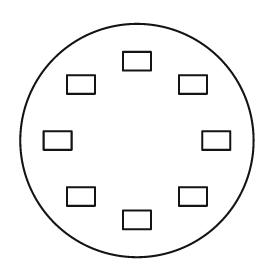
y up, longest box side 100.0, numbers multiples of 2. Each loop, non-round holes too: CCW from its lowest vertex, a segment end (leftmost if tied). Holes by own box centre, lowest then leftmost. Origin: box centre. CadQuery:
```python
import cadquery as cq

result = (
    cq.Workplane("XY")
    .moveTo(0.0, 0.0)
    .circle(50.0)
    .moveTo(-6.0, -38.0)
    .lineTo(6.0, -38.0)
    .lineTo(6.0, -30.0)
    .lineTo(-6.0, -30.0)
    .close()
    .moveTo(-30.0, -28.0)
    .lineTo(-18.0, -28.0)
    .lineTo(-18.0, -20.0)
    .lineTo(-30.0, -20.0)
    .close()
    .moveTo(18.0, -28.0)
    .lineTo(30.0, -28.0)
    .lineTo(30.0, -20.0)
    .lineTo(18.0, -20.0)
    .close()
    .moveTo(-40.0, -4.0)
    .lineTo(-28.0, -4.0)
    .lineTo(-28.0, 4.0)
    .lineTo(-40.0, 4.0)
    .close()
    .moveTo(28.0, -4.0)
    .lineTo(40.0, -4.0)
    .lineTo(40.0, 4.0)
    .lineTo(28.0, 4.0)
    .close()
    .moveTo(-30.0, 20.0)
    .lineTo(-18.0, 20.0)
    .lineTo(-18.0, 28.0)
    .lineTo(-30.0, 28.0)
    .close()
    .moveTo(18.0, 20.0)
    .lineTo(30.0, 20.0)
    .lineTo(30.0, 28.0)
    .lineTo(18.0, 28.0)
    .close()
    .moveTo(-6.0, 30.0)
    .lineTo(6.0, 30.0)
    .lineTo(6.0, 38.0)
    .lineTo(-6.0, 38.0)
    .close()
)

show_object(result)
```